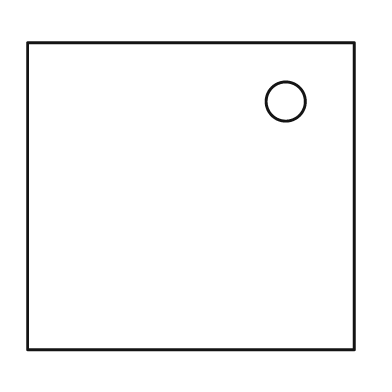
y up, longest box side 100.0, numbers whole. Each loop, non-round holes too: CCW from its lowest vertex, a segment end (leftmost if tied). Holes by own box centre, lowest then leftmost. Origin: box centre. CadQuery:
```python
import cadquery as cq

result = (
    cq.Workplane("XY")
    .moveTo(-50.0, -47.0)
    .lineTo(50.0, -47.0)
    .lineTo(50.0, 47.0)
    .lineTo(-50.0, 47.0)
    .close()
    .moveTo(29.0, 29.0)
    .circle(6.0)
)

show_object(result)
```